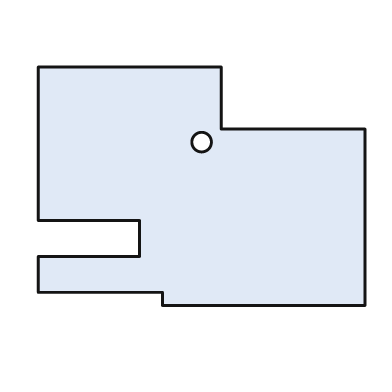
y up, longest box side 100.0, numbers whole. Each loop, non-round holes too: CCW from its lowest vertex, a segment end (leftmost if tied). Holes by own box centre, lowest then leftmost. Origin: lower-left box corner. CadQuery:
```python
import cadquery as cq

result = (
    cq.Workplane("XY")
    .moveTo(38.0, 0.0)
    .lineTo(100.0, 0.0)
    .lineTo(100.0, 54.0)
    .lineTo(56.0, 54.0)
    .lineTo(56.0, 73.0)
    .lineTo(0.0, 73.0)
    .lineTo(0.0, 26.0)
    .lineTo(31.0, 26.0)
    .lineTo(31.0, 15.0)
    .lineTo(0.0, 15.0)
    .lineTo(0.0, 4.0)
    .lineTo(38.0, 4.0)
    .close()
    .moveTo(50.0, 50.0)
    .circle(3.0)
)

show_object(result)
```